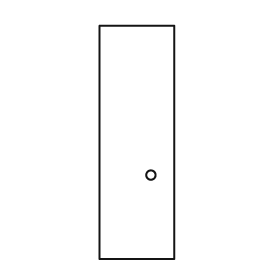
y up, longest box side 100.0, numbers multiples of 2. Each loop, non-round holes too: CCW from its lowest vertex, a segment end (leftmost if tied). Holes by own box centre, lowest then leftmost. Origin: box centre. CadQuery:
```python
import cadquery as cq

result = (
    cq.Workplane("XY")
    .moveTo(-16.0, -50.0)
    .lineTo(16.0, -50.0)
    .lineTo(16.0, 50.0)
    .lineTo(-16.0, 50.0)
    .close()
    .moveTo(6.0, -14.0)
    .circle(2.0)
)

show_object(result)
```